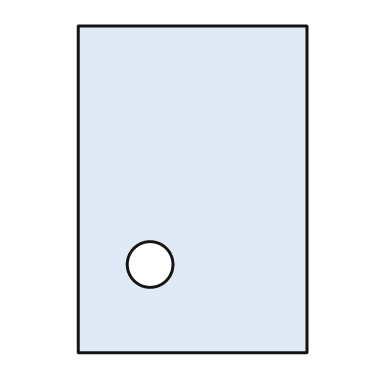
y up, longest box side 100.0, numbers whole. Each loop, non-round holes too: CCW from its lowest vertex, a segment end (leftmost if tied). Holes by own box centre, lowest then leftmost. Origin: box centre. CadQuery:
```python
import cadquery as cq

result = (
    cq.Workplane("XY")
    .moveTo(-35.0, -50.0)
    .lineTo(35.0, -50.0)
    .lineTo(35.0, 50.0)
    .lineTo(-35.0, 50.0)
    .close()
    .moveTo(-13.0, -23.0)
    .circle(7.0)
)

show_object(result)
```